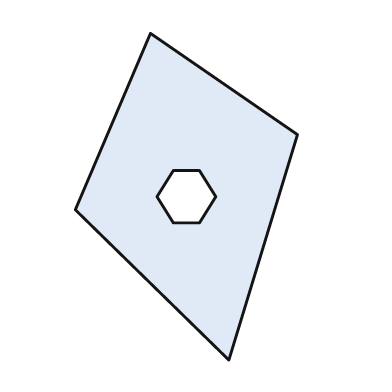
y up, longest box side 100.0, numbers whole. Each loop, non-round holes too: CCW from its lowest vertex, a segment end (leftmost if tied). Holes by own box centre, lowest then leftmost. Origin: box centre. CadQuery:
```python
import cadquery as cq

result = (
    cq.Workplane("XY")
    .moveTo(13.0, -50.0)
    .lineTo(34.0, 19.0)
    .lineTo(-11.0, 50.0)
    .lineTo(-34.0, -4.0)
    .close()
    .moveTo(-4.0, -8.0)
    .lineTo(4.0, -8.0)
    .lineTo(9.0, 0.0)
    .lineTo(4.0, 8.0)
    .lineTo(-4.0, 8.0)
    .lineTo(-9.0, 0.0)
    .close()
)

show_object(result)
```